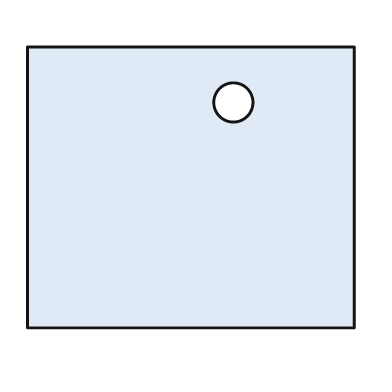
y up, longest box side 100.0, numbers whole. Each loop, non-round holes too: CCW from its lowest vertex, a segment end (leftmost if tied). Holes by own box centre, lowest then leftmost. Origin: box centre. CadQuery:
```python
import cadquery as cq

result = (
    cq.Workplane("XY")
    .moveTo(-50.0, -43.0)
    .lineTo(50.0, -43.0)
    .lineTo(50.0, 43.0)
    .lineTo(-50.0, 43.0)
    .close()
    .moveTo(13.0, 26.0)
    .circle(6.0)
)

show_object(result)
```